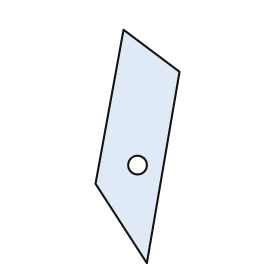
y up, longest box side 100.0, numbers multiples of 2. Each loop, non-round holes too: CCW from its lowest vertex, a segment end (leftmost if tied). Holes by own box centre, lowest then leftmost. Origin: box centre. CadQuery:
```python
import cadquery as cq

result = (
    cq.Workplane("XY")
    .moveTo(4.0, -50.0)
    .lineTo(18.0, 32.0)
    .lineTo(-6.0, 50.0)
    .lineTo(-18.0, -16.0)
    .close()
    .moveTo(0.0, -8.0)
    .circle(4.0)
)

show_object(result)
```